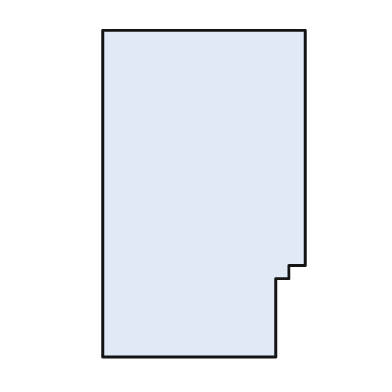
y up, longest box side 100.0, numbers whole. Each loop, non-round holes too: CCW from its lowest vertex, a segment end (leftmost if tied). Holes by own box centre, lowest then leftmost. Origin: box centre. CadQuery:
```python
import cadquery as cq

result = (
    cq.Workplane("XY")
    .moveTo(-31.0, -50.0)
    .lineTo(22.0, -50.0)
    .lineTo(22.0, -26.0)
    .lineTo(26.0, -26.0)
    .lineTo(26.0, -22.0)
    .lineTo(31.0, -22.0)
    .lineTo(31.0, 50.0)
    .lineTo(-31.0, 50.0)
    .close()
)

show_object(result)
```